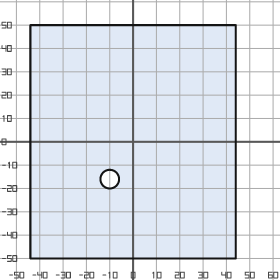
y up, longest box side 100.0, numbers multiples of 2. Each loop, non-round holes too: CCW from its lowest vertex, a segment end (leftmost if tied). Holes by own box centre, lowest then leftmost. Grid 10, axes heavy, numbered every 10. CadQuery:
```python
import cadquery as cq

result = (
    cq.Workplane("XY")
    .moveTo(-44.0, -50.0)
    .lineTo(44.0, -50.0)
    .lineTo(44.0, 50.0)
    .lineTo(-44.0, 50.0)
    .close()
    .moveTo(-10.0, -16.0)
    .circle(4.0)
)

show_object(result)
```